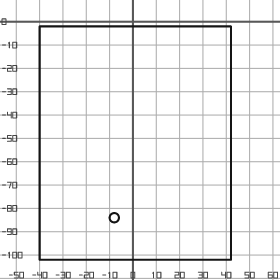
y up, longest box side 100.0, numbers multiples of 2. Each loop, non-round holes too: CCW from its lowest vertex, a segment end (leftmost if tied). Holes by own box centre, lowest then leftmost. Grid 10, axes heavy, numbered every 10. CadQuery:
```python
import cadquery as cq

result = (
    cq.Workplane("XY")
    .moveTo(-40.0, -102.0)
    .lineTo(42.0, -102.0)
    .lineTo(42.0, -2.0)
    .lineTo(-40.0, -2.0)
    .close()
    .moveTo(-8.0, -84.0)
    .circle(2.0)
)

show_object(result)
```